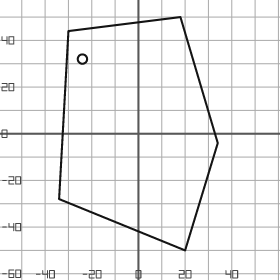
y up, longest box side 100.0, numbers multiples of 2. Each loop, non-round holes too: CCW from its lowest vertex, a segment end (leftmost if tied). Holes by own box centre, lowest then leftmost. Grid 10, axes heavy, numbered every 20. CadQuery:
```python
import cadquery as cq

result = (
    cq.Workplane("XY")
    .moveTo(20.0, -50.0)
    .lineTo(34.0, -4.0)
    .lineTo(18.0, 50.0)
    .lineTo(-30.0, 44.0)
    .lineTo(-34.0, -28.0)
    .close()
    .moveTo(-24.0, 32.0)
    .circle(2.0)
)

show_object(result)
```